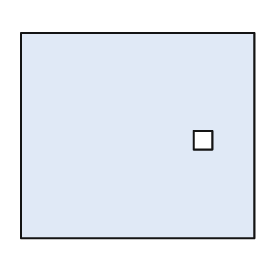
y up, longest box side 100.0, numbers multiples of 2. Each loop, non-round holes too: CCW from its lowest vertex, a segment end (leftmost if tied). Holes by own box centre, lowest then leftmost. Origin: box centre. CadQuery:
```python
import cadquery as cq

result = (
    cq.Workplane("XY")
    .moveTo(-50.0, -44.0)
    .lineTo(50.0, -44.0)
    .lineTo(50.0, 44.0)
    .lineTo(-50.0, 44.0)
    .close()
    .moveTo(24.0, -6.0)
    .lineTo(32.0, -6.0)
    .lineTo(32.0, 2.0)
    .lineTo(24.0, 2.0)
    .close()
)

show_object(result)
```